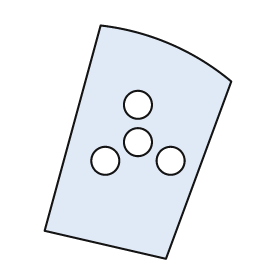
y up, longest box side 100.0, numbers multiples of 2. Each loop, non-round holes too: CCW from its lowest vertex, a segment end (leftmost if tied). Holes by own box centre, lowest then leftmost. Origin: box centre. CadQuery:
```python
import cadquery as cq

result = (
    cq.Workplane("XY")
    .moveTo(12.0, -50.0)
    .lineTo(40.0, 26.0)
    .threePointArc((14.0, 42.0), (-16.0, 50.0))
    .lineTo(-40.0, -38.0)
    .close()
    .moveTo(-14.0, -8.0)
    .circle(6.0)
    .moveTo(14.0, -8.0)
    .circle(6.0)
    .moveTo(0.0, 0.0)
    .circle(6.0)
    .moveTo(0.0, 16.0)
    .circle(6.0)
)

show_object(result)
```